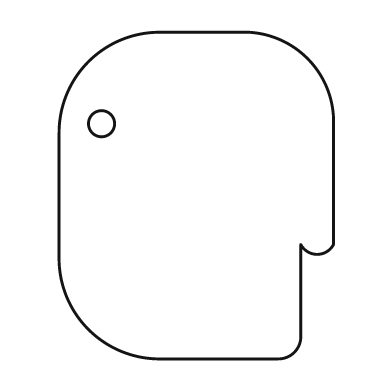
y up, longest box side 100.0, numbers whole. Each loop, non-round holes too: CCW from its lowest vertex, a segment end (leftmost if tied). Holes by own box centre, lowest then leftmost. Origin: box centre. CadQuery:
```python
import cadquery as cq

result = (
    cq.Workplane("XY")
    .moveTo(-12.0, -50.0)
    .lineTo(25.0, -50.0)
    .threePointArc((30.0, -48.0), (32.0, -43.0))
    .lineTo(32.0, -15.0)
    .threePointArc((37.0, -18.0), (42.0, -15.0))
    .lineTo(42.0, 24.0)
    .threePointArc((34.0, 42.0), (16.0, 50.0))
    .lineTo(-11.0, 50.0)
    .threePointArc((-33.0, 41.0), (-42.0, 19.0))
    .lineTo(-42.0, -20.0)
    .threePointArc((-33.0, -41.0), (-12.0, -50.0))
    .close()
    .moveTo(-29.0, 22.0)
    .circle(4.0)
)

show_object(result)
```